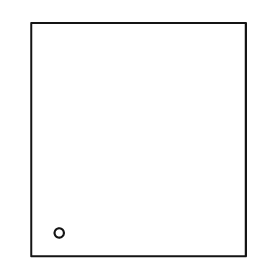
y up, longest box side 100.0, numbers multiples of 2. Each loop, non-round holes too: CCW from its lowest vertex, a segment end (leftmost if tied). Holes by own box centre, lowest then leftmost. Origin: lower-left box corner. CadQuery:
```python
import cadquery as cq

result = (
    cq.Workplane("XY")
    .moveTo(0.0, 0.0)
    .lineTo(92.0, 0.0)
    .lineTo(92.0, 100.0)
    .lineTo(0.0, 100.0)
    .close()
    .moveTo(12.0, 10.0)
    .circle(2.0)
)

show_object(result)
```